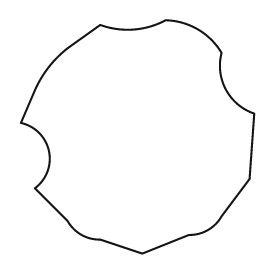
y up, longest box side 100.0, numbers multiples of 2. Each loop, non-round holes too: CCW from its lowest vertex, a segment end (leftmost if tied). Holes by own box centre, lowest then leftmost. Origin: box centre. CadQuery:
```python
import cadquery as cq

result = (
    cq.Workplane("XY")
    .moveTo(2.0, -50.0)
    .lineTo(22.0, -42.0)
    .threePointArc((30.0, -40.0), (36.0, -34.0))
    .lineTo(48.0, -18.0)
    .lineTo(50.0, 10.0)
    .threePointArc((38.0, 20.0), (36.0, 36.0))
    .threePointArc((26.0, 46.0), (12.0, 50.0))
    .threePointArc((-2.0, 46.0), (-16.0, 48.0))
    .lineTo(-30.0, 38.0)
    .threePointArc((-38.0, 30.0), (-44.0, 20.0))
    .lineTo(-50.0, 6.0)
    .threePointArc((-38.0, -6.0), (-44.0, -22.0))
    .lineTo(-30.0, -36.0)
    .threePointArc((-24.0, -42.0), (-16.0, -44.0))
    .close()
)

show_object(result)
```